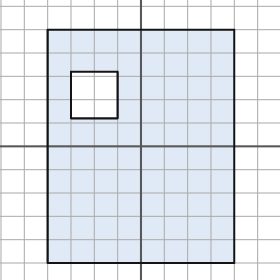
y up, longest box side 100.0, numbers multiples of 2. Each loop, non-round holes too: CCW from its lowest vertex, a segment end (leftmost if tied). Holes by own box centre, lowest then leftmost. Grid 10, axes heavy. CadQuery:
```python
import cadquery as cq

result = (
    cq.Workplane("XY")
    .moveTo(-40.0, -50.0)
    .lineTo(40.0, -50.0)
    .lineTo(40.0, 50.0)
    .lineTo(-40.0, 50.0)
    .close()
    .moveTo(-30.0, 12.0)
    .lineTo(-10.0, 12.0)
    .lineTo(-10.0, 32.0)
    .lineTo(-30.0, 32.0)
    .close()
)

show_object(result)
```